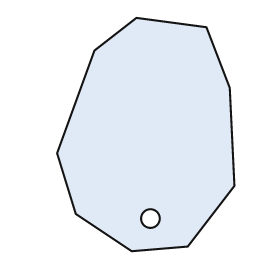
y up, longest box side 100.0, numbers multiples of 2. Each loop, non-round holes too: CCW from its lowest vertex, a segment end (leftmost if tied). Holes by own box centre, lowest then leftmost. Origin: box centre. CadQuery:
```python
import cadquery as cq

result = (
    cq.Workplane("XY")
    .moveTo(-6.0, -50.0)
    .lineTo(18.0, -48.0)
    .lineTo(38.0, -22.0)
    .lineTo(36.0, 20.0)
    .lineTo(26.0, 46.0)
    .lineTo(-4.0, 50.0)
    .lineTo(-22.0, 36.0)
    .lineTo(-38.0, -8.0)
    .lineTo(-30.0, -34.0)
    .close()
    .moveTo(2.0, -36.0)
    .circle(4.0)
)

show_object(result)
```